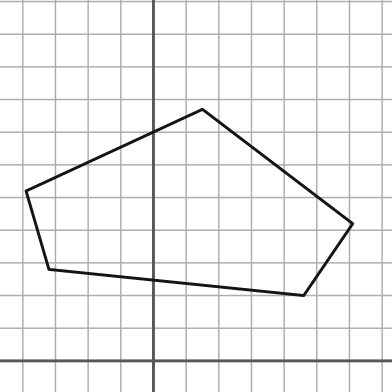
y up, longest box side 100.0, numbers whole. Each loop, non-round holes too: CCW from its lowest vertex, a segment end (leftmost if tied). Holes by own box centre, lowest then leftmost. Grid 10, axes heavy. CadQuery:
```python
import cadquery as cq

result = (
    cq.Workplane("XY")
    .moveTo(46.0, 20.0)
    .lineTo(61.0, 42.0)
    .lineTo(15.0, 77.0)
    .lineTo(-39.0, 52.0)
    .lineTo(-32.0, 28.0)
    .close()
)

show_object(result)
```